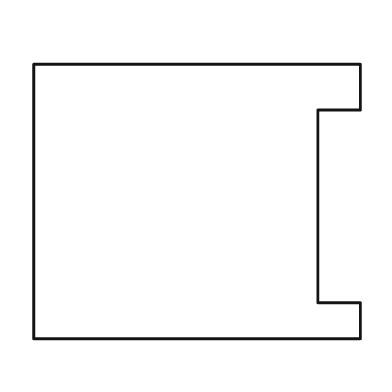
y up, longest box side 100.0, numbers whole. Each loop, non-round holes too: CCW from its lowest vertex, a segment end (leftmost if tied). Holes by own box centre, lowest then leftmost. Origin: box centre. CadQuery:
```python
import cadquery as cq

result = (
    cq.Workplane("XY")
    .moveTo(-50.0, -42.0)
    .lineTo(50.0, -42.0)
    .lineTo(50.0, -31.0)
    .lineTo(37.0, -31.0)
    .lineTo(37.0, 28.0)
    .lineTo(50.0, 28.0)
    .lineTo(50.0, 42.0)
    .lineTo(-50.0, 42.0)
    .close()
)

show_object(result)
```